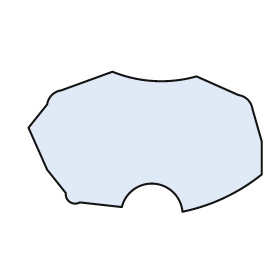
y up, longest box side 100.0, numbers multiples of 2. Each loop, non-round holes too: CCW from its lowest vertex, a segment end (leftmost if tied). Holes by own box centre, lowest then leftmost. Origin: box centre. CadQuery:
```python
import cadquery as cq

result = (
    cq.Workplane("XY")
    .moveTo(16.0, -30.0)
    .threePointArc((34.0, -24.0), (50.0, -14.0))
    .lineTo(50.0, 0.0)
    .lineTo(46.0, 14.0)
    .threePointArc((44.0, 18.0), (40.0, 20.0))
    .lineTo(22.0, 28.0)
    .threePointArc((4.0, 26.0), (-14.0, 30.0))
    .lineTo(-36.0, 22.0)
    .threePointArc((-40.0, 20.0), (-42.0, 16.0))
    .lineTo(-50.0, 6.0)
    .lineTo(-42.0, -12.0)
    .lineTo(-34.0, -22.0)
    .threePointArc((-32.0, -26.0), (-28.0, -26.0))
    .lineTo(-10.0, -28.0)
    .threePointArc((4.0, -18.0), (16.0, -30.0))
    .close()
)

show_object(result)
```